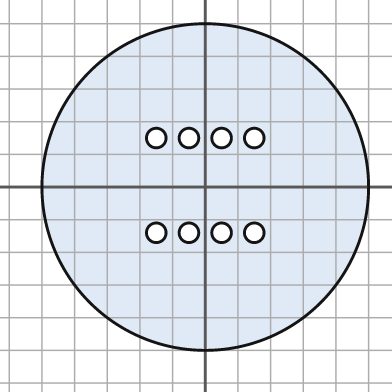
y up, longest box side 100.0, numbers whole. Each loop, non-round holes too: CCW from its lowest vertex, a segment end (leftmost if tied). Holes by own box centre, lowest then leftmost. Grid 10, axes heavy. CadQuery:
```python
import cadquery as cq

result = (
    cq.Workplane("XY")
    .moveTo(0.0, 0.0)
    .circle(50.0)
    .moveTo(-15.0, -14.0)
    .circle(3.0)
    .moveTo(-5.0, -14.0)
    .circle(3.0)
    .moveTo(5.0, -14.0)
    .circle(3.0)
    .moveTo(15.0, -14.0)
    .circle(3.0)
    .moveTo(-15.0, 15.0)
    .circle(3.0)
    .moveTo(-5.0, 15.0)
    .circle(3.0)
    .moveTo(5.0, 15.0)
    .circle(3.0)
    .moveTo(15.0, 15.0)
    .circle(3.0)
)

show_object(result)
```